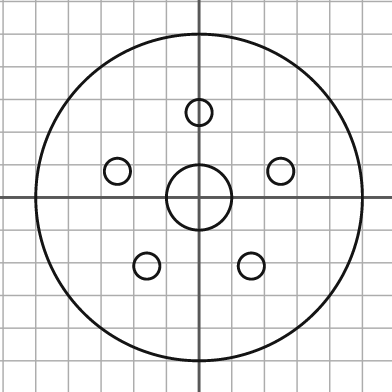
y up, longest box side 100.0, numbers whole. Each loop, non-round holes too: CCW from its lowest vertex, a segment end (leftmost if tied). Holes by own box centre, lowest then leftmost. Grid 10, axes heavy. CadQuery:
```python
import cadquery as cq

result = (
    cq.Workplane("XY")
    .moveTo(0.0, 0.0)
    .circle(50.0)
    .moveTo(-16.0, -21.0)
    .circle(4.0)
    .moveTo(16.0, -21.0)
    .circle(4.0)
    .moveTo(0.0, 0.0)
    .circle(10.0)
    .moveTo(-25.0, 8.0)
    .circle(4.0)
    .moveTo(25.0, 8.0)
    .circle(4.0)
    .moveTo(0.0, 26.0)
    .circle(4.0)
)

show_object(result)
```